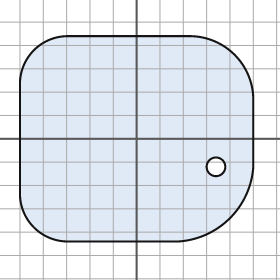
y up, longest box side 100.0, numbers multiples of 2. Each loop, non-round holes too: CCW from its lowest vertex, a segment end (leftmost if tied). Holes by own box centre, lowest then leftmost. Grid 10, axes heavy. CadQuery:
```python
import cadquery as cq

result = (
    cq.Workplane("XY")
    .moveTo(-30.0, -44.0)
    .lineTo(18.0, -44.0)
    .threePointArc((40.0, -34.0), (50.0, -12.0))
    .lineTo(50.0, 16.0)
    .threePointArc((42.0, 36.0), (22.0, 44.0))
    .lineTo(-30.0, 44.0)
    .threePointArc((-44.0, 38.0), (-50.0, 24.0))
    .lineTo(-50.0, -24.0)
    .threePointArc((-44.0, -38.0), (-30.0, -44.0))
    .close()
    .moveTo(34.0, -12.0)
    .circle(4.0)
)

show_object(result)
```